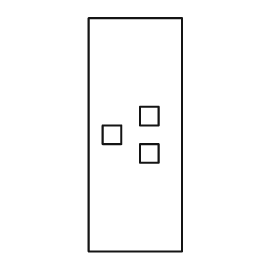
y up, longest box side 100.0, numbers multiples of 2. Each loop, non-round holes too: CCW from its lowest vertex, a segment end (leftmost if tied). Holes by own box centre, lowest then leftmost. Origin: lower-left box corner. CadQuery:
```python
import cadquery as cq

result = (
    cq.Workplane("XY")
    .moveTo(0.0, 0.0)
    .lineTo(40.0, 0.0)
    .lineTo(40.0, 100.0)
    .lineTo(0.0, 100.0)
    .close()
    .moveTo(22.0, 38.0)
    .lineTo(30.0, 38.0)
    .lineTo(30.0, 46.0)
    .lineTo(22.0, 46.0)
    .close()
    .moveTo(6.0, 46.0)
    .lineTo(14.0, 46.0)
    .lineTo(14.0, 54.0)
    .lineTo(6.0, 54.0)
    .close()
    .moveTo(22.0, 54.0)
    .lineTo(30.0, 54.0)
    .lineTo(30.0, 62.0)
    .lineTo(22.0, 62.0)
    .close()
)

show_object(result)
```